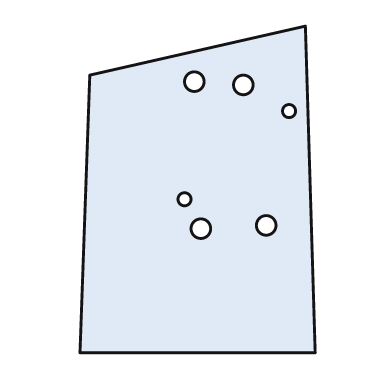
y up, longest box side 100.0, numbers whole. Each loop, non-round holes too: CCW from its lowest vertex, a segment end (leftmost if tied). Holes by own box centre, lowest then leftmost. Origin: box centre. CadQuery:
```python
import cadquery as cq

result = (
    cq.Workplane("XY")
    .moveTo(-36.0, -50.0)
    .lineTo(36.0, -50.0)
    .lineTo(33.0, 50.0)
    .lineTo(-33.0, 35.0)
    .close()
    .moveTo(1.0, -12.0)
    .circle(3.0)
    .moveTo(21.0, -11.0)
    .circle(3.0)
    .moveTo(-4.0, -3.0)
    .circle(2.0)
    .moveTo(28.0, 24.0)
    .circle(2.0)
    .moveTo(14.0, 32.0)
    .circle(3.0)
    .moveTo(-1.0, 33.0)
    .circle(3.0)
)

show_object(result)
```